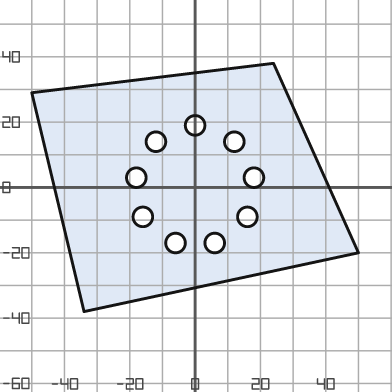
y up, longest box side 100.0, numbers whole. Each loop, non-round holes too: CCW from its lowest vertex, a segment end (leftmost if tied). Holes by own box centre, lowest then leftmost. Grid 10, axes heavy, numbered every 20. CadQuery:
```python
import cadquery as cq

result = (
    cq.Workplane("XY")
    .moveTo(-34.0, -38.0)
    .lineTo(50.0, -20.0)
    .lineTo(24.0, 38.0)
    .lineTo(-50.0, 29.0)
    .close()
    .moveTo(-6.0, -17.0)
    .circle(3.0)
    .moveTo(6.0, -17.0)
    .circle(3.0)
    .moveTo(-16.0, -9.0)
    .circle(3.0)
    .moveTo(16.0, -9.0)
    .circle(3.0)
    .moveTo(-18.0, 3.0)
    .circle(3.0)
    .moveTo(18.0, 3.0)
    .circle(3.0)
    .moveTo(-12.0, 14.0)
    .circle(3.0)
    .moveTo(12.0, 14.0)
    .circle(3.0)
    .moveTo(0.0, 19.0)
    .circle(3.0)
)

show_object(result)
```